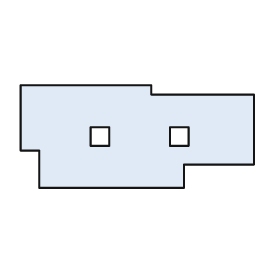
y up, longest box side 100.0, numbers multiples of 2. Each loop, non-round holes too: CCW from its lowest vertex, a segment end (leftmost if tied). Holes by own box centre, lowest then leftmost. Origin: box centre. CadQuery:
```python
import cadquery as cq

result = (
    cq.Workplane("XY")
    .moveTo(-42.0, -22.0)
    .lineTo(20.0, -22.0)
    .lineTo(20.0, -12.0)
    .lineTo(50.0, -12.0)
    .lineTo(50.0, 18.0)
    .lineTo(6.0, 18.0)
    .lineTo(6.0, 22.0)
    .lineTo(-50.0, 22.0)
    .lineTo(-50.0, -6.0)
    .lineTo(-42.0, -6.0)
    .close()
    .moveTo(-20.0, -4.0)
    .lineTo(-12.0, -4.0)
    .lineTo(-12.0, 4.0)
    .lineTo(-20.0, 4.0)
    .close()
    .moveTo(14.0, -4.0)
    .lineTo(22.0, -4.0)
    .lineTo(22.0, 4.0)
    .lineTo(14.0, 4.0)
    .close()
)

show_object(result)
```